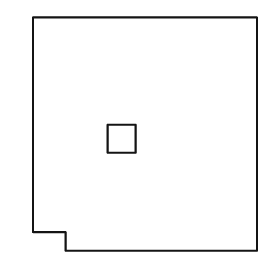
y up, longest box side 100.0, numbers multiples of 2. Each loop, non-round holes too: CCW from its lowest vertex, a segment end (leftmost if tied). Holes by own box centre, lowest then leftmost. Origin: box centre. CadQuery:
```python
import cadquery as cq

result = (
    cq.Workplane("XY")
    .moveTo(-34.0, -50.0)
    .lineTo(48.0, -50.0)
    .lineTo(48.0, 50.0)
    .lineTo(-48.0, 50.0)
    .lineTo(-48.0, -42.0)
    .lineTo(-34.0, -42.0)
    .close()
    .moveTo(-16.0, -8.0)
    .lineTo(-4.0, -8.0)
    .lineTo(-4.0, 4.0)
    .lineTo(-16.0, 4.0)
    .close()
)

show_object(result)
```